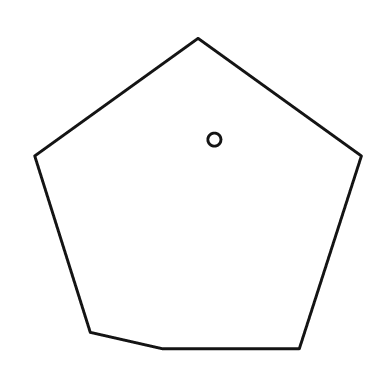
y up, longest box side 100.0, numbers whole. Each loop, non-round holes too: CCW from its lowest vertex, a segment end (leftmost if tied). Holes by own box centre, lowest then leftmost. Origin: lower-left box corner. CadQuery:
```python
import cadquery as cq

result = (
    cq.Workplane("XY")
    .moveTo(39.0, 0.0)
    .lineTo(81.0, 0.0)
    .lineTo(100.0, 59.0)
    .lineTo(50.0, 95.0)
    .lineTo(0.0, 59.0)
    .lineTo(17.0, 5.0)
    .close()
    .moveTo(55.0, 64.0)
    .circle(2.0)
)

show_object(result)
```